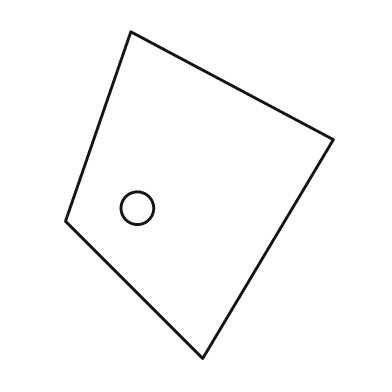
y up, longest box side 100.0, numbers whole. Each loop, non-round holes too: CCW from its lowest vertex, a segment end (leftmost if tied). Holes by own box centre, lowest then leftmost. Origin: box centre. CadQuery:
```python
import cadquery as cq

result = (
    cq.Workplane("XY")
    .moveTo(1.0, -50.0)
    .lineTo(41.0, 17.0)
    .lineTo(-21.0, 50.0)
    .lineTo(-41.0, -8.0)
    .close()
    .moveTo(-19.0, -4.0)
    .circle(5.0)
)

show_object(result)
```